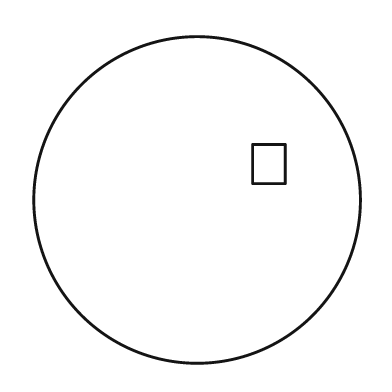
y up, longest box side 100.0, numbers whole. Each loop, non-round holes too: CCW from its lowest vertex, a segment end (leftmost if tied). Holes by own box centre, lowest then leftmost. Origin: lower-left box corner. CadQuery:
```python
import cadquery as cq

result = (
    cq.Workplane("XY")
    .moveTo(50.0, 50.0)
    .circle(50.0)
    .moveTo(67.0, 55.0)
    .lineTo(77.0, 55.0)
    .lineTo(77.0, 67.0)
    .lineTo(67.0, 67.0)
    .close()
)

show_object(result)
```